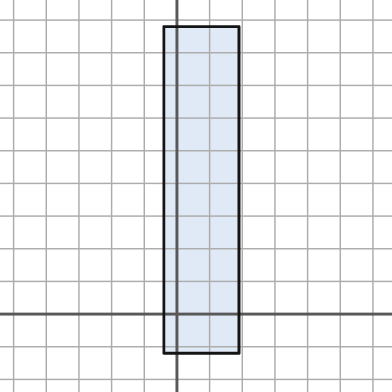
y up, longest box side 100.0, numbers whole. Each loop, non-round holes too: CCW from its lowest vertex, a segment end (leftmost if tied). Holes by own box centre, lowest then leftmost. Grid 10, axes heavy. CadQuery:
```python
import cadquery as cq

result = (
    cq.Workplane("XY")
    .moveTo(-4.0, -12.0)
    .lineTo(19.0, -12.0)
    .lineTo(19.0, 88.0)
    .lineTo(-4.0, 88.0)
    .close()
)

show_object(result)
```